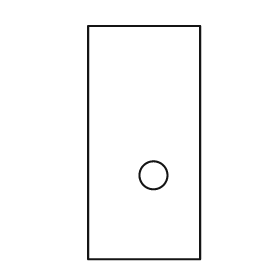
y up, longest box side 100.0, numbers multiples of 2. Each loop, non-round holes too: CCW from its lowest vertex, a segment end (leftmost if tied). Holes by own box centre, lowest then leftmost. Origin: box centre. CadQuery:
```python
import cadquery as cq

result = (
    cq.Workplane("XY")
    .moveTo(-24.0, -50.0)
    .lineTo(24.0, -50.0)
    .lineTo(24.0, 50.0)
    .lineTo(-24.0, 50.0)
    .close()
    .moveTo(4.0, -14.0)
    .circle(6.0)
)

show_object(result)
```